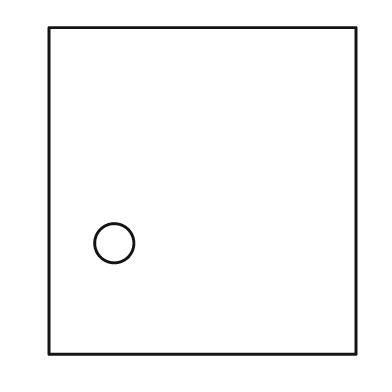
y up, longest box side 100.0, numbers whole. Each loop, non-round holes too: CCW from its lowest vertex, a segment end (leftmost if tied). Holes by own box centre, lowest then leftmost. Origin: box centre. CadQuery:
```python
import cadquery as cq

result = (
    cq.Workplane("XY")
    .moveTo(-47.0, -50.0)
    .lineTo(47.0, -50.0)
    .lineTo(47.0, 50.0)
    .lineTo(-47.0, 50.0)
    .close()
    .moveTo(-27.0, -16.0)
    .circle(6.0)
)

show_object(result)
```